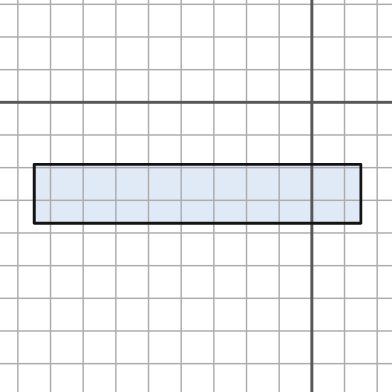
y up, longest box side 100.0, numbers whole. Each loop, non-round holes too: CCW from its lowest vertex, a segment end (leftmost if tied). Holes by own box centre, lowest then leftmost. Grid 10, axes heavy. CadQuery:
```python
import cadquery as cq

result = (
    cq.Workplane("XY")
    .moveTo(-85.0, -37.0)
    .lineTo(15.0, -37.0)
    .lineTo(15.0, -19.0)
    .lineTo(-85.0, -19.0)
    .close()
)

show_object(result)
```